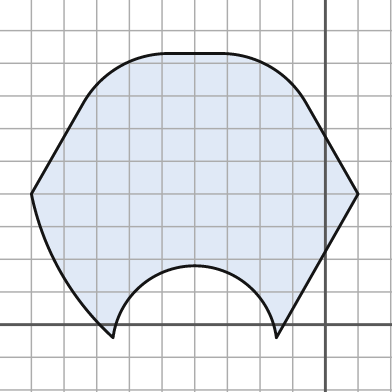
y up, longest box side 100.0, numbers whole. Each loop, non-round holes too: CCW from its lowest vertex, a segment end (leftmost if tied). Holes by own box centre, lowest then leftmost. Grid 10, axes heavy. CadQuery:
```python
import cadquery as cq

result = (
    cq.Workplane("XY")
    .moveTo(-65.0, -4.0)
    .threePointArc((-40.0, 18.0), (-15.0, -4.0))
    .lineTo(10.0, 40.0)
    .lineTo(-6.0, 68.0)
    .threePointArc((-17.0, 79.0), (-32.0, 83.0))
    .lineTo(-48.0, 83.0)
    .threePointArc((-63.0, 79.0), (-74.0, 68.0))
    .lineTo(-90.0, 40.0)
    .threePointArc((-81.0, 16.0), (-65.0, -4.0))
    .close()
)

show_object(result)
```